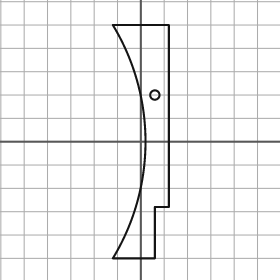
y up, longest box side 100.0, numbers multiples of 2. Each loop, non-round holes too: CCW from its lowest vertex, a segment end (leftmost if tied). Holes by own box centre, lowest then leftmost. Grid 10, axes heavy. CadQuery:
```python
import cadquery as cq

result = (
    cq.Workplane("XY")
    .moveTo(-12.0, -50.0)
    .lineTo(6.0, -50.0)
    .lineTo(6.0, -28.0)
    .lineTo(12.0, -28.0)
    .lineTo(12.0, 50.0)
    .lineTo(-12.0, 50.0)
    .threePointArc((2.0, 0.0), (-12.0, -50.0))
    .close()
    .moveTo(6.0, 20.0)
    .circle(2.0)
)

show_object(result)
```